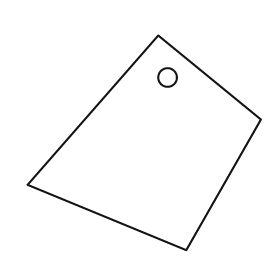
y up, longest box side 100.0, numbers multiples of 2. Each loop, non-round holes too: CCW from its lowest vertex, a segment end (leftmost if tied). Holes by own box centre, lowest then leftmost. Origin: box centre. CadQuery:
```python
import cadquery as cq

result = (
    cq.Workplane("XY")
    .moveTo(18.0, -46.0)
    .lineTo(50.0, 10.0)
    .lineTo(6.0, 46.0)
    .lineTo(-50.0, -18.0)
    .close()
    .moveTo(10.0, 28.0)
    .circle(4.0)
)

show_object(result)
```